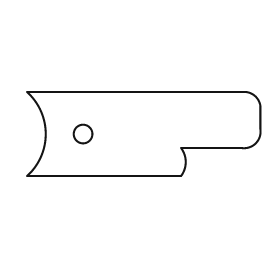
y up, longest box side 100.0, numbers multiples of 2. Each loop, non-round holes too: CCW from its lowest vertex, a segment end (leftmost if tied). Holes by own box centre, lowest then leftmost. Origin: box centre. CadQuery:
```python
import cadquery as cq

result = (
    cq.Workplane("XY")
    .moveTo(-50.0, -18.0)
    .lineTo(16.0, -18.0)
    .threePointArc((18.0, -12.0), (16.0, -6.0))
    .lineTo(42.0, -6.0)
    .threePointArc((48.0, -4.0), (50.0, 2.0))
    .lineTo(50.0, 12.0)
    .threePointArc((48.0, 16.0), (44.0, 18.0))
    .lineTo(-50.0, 18.0)
    .threePointArc((-42.0, 0.0), (-50.0, -18.0))
    .close()
    .moveTo(-26.0, 0.0)
    .circle(4.0)
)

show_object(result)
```